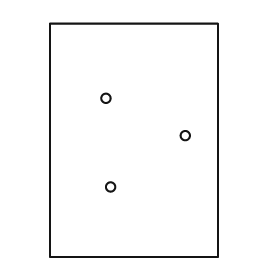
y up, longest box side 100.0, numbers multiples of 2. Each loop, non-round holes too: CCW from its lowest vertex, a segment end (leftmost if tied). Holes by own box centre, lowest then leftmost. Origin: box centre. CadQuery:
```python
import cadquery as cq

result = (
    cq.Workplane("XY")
    .moveTo(-36.0, -50.0)
    .lineTo(36.0, -50.0)
    .lineTo(36.0, 50.0)
    .lineTo(-36.0, 50.0)
    .close()
    .moveTo(-10.0, -20.0)
    .circle(2.0)
    .moveTo(22.0, 2.0)
    .circle(2.0)
    .moveTo(-12.0, 18.0)
    .circle(2.0)
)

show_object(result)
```